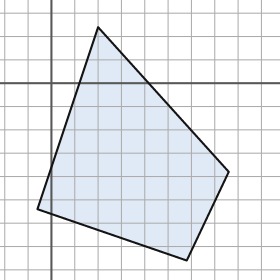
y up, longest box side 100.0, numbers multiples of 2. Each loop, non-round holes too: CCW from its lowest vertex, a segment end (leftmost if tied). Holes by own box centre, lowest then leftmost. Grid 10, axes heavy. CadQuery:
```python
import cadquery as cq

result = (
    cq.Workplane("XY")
    .moveTo(58.0, -76.0)
    .lineTo(76.0, -38.0)
    .lineTo(20.0, 24.0)
    .lineTo(-6.0, -54.0)
    .close()
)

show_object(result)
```